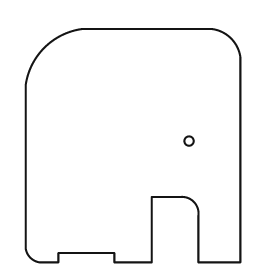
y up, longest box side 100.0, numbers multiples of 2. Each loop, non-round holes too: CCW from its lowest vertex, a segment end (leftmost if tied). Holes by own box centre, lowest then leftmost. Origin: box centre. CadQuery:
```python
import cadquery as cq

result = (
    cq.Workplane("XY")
    .moveTo(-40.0, -50.0)
    .lineTo(-32.0, -50.0)
    .lineTo(-32.0, -46.0)
    .lineTo(-8.0, -46.0)
    .lineTo(-8.0, -50.0)
    .lineTo(8.0, -50.0)
    .lineTo(8.0, -22.0)
    .lineTo(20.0, -22.0)
    .threePointArc((26.0, -24.0), (28.0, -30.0))
    .lineTo(28.0, -50.0)
    .lineTo(46.0, -50.0)
    .lineTo(46.0, 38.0)
    .threePointArc((42.0, 46.0), (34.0, 50.0))
    .lineTo(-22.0, 50.0)
    .threePointArc((-38.0, 42.0), (-46.0, 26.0))
    .lineTo(-46.0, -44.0)
    .threePointArc((-44.0, -48.0), (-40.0, -50.0))
    .close()
    .moveTo(24.0, 2.0)
    .circle(2.0)
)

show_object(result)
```